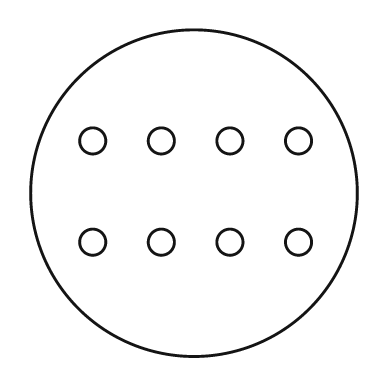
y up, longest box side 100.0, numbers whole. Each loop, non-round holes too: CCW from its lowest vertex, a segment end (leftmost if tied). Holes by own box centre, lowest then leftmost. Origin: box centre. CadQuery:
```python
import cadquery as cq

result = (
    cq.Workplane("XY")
    .moveTo(0.0, 0.0)
    .circle(50.0)
    .moveTo(-31.0, -15.0)
    .circle(4.0)
    .moveTo(-10.0, -15.0)
    .circle(4.0)
    .moveTo(11.0, -15.0)
    .circle(4.0)
    .moveTo(32.0, -15.0)
    .circle(4.0)
    .moveTo(-31.0, 16.0)
    .circle(4.0)
    .moveTo(-10.0, 16.0)
    .circle(4.0)
    .moveTo(11.0, 16.0)
    .circle(4.0)
    .moveTo(32.0, 16.0)
    .circle(4.0)
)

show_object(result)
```